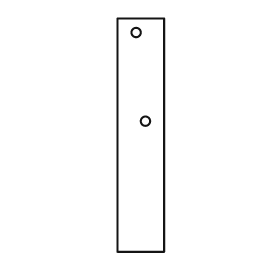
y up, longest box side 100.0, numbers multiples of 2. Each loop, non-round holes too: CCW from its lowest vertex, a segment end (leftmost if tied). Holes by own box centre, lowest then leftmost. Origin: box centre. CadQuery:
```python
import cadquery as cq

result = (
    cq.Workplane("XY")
    .moveTo(-10.0, -50.0)
    .lineTo(10.0, -50.0)
    .lineTo(10.0, 50.0)
    .lineTo(-10.0, 50.0)
    .close()
    .moveTo(2.0, 6.0)
    .circle(2.0)
    .moveTo(-2.0, 44.0)
    .circle(2.0)
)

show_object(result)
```